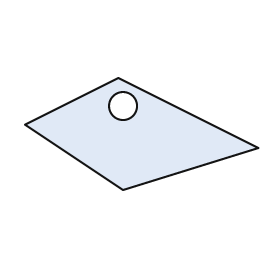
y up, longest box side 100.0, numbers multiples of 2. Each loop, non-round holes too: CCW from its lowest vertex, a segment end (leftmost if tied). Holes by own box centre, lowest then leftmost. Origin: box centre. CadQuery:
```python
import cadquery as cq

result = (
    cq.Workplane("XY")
    .moveTo(-8.0, -24.0)
    .lineTo(50.0, -6.0)
    .lineTo(-10.0, 24.0)
    .lineTo(-50.0, 4.0)
    .close()
    .moveTo(-8.0, 12.0)
    .circle(6.0)
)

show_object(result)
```